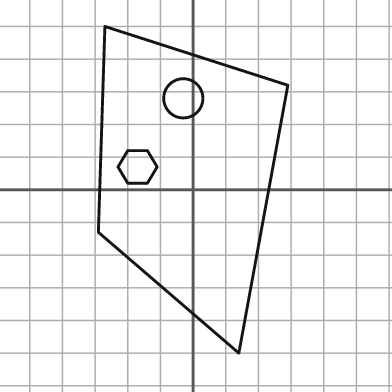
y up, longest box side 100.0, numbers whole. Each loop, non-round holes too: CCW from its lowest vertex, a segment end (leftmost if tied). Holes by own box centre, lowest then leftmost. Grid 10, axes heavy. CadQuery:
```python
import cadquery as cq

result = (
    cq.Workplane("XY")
    .moveTo(14.0, -50.0)
    .lineTo(29.0, 32.0)
    .lineTo(-27.0, 50.0)
    .lineTo(-29.0, -13.0)
    .close()
    .moveTo(-20.0, 2.0)
    .lineTo(-14.0, 2.0)
    .lineTo(-11.0, 7.0)
    .lineTo(-14.0, 12.0)
    .lineTo(-20.0, 12.0)
    .lineTo(-23.0, 7.0)
    .close()
    .moveTo(-3.0, 28.0)
    .circle(6.0)
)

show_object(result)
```